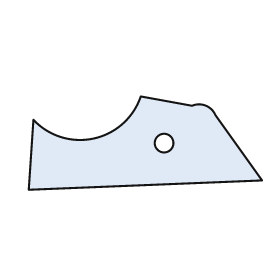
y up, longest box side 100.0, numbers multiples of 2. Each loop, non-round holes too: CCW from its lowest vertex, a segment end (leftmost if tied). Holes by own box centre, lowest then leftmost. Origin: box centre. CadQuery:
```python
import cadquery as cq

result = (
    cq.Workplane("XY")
    .moveTo(-50.0, -20.0)
    .lineTo(50.0, -16.0)
    .lineTo(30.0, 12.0)
    .threePointArc((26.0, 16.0), (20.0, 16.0))
    .lineTo(-2.0, 20.0)
    .threePointArc((-22.0, 2.0), (-48.0, 10.0))
    .close()
    .moveTo(8.0, 0.0)
    .circle(4.0)
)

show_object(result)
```